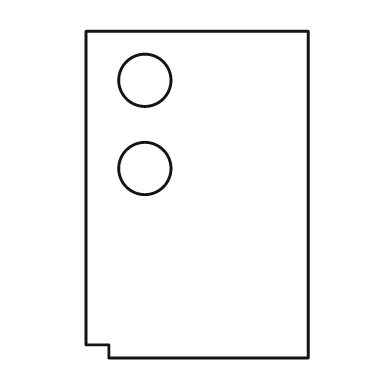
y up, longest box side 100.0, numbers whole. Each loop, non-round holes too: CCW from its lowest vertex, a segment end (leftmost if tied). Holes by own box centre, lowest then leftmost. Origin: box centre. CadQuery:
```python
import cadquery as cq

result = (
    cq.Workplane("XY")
    .moveTo(-27.0, -50.0)
    .lineTo(34.0, -50.0)
    .lineTo(34.0, 50.0)
    .lineTo(-34.0, 50.0)
    .lineTo(-34.0, -46.0)
    .lineTo(-27.0, -46.0)
    .close()
    .moveTo(-16.0, 8.0)
    .circle(8.0)
    .moveTo(-16.0, 35.0)
    .circle(8.0)
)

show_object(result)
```